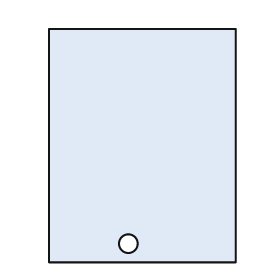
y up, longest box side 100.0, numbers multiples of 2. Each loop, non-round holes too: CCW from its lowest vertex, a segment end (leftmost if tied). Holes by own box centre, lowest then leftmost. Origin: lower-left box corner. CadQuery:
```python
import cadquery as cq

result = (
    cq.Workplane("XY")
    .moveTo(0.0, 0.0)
    .lineTo(80.0, 0.0)
    .lineTo(80.0, 100.0)
    .lineTo(0.0, 100.0)
    .close()
    .moveTo(34.0, 8.0)
    .circle(4.0)
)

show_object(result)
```